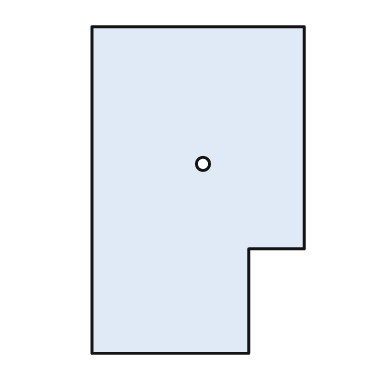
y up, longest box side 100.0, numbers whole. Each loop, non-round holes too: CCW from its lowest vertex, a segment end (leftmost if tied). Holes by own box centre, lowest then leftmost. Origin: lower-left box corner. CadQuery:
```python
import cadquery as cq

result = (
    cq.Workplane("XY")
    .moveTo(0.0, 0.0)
    .lineTo(48.0, 0.0)
    .lineTo(48.0, 32.0)
    .lineTo(65.0, 32.0)
    .lineTo(65.0, 100.0)
    .lineTo(0.0, 100.0)
    .close()
    .moveTo(34.0, 58.0)
    .circle(2.0)
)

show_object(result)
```